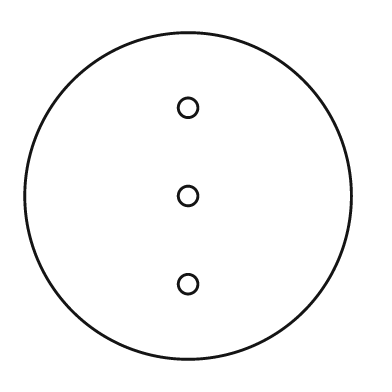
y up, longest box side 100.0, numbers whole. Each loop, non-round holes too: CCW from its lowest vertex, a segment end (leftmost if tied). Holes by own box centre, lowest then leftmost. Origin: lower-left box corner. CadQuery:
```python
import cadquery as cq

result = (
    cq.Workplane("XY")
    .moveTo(50.0, 50.0)
    .circle(50.0)
    .moveTo(50.0, 23.0)
    .circle(3.0)
    .moveTo(50.0, 50.0)
    .circle(3.0)
    .moveTo(50.0, 77.0)
    .circle(3.0)
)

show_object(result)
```